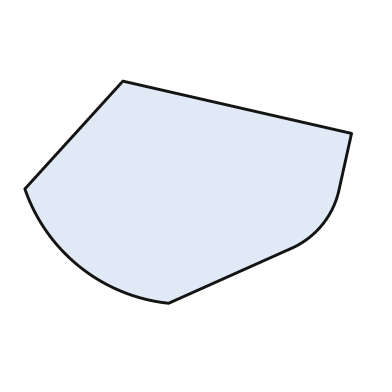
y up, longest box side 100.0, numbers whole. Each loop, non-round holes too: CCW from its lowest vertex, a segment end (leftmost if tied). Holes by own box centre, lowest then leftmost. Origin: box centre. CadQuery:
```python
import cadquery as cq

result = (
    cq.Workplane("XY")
    .moveTo(-6.0, -34.0)
    .lineTo(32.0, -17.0)
    .threePointArc((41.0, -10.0), (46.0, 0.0))
    .lineTo(50.0, 18.0)
    .lineTo(-20.0, 34.0)
    .lineTo(-50.0, 1.0)
    .threePointArc((-33.0, -23.0), (-6.0, -34.0))
    .close()
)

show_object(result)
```